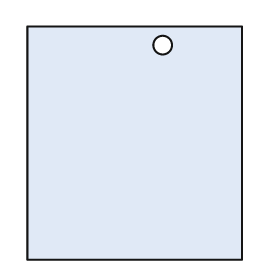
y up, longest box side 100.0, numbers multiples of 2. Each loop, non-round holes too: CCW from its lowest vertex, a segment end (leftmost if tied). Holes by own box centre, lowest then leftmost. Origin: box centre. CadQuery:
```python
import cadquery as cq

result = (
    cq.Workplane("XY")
    .moveTo(-46.0, -50.0)
    .lineTo(46.0, -50.0)
    .lineTo(46.0, 50.0)
    .lineTo(-46.0, 50.0)
    .close()
    .moveTo(12.0, 42.0)
    .circle(4.0)
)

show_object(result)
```